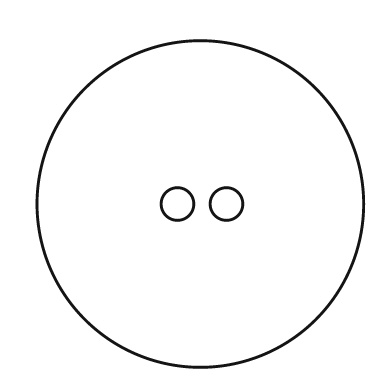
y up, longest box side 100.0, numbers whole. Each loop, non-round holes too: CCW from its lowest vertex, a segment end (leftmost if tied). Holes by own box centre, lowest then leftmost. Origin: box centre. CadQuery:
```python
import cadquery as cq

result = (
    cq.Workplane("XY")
    .moveTo(0.0, 0.0)
    .circle(50.0)
    .moveTo(-7.0, 0.0)
    .circle(5.0)
    .moveTo(8.0, 0.0)
    .circle(5.0)
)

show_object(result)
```